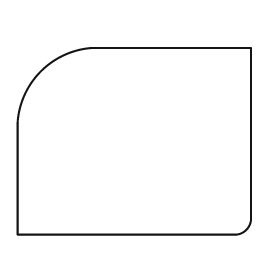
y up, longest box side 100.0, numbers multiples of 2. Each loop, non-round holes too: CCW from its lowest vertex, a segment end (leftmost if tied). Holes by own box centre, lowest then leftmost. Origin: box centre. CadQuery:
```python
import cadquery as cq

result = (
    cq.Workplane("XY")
    .moveTo(-50.0, -40.0)
    .lineTo(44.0, -40.0)
    .threePointArc((48.0, -38.0), (50.0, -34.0))
    .lineTo(50.0, 40.0)
    .lineTo(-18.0, 40.0)
    .threePointArc((-40.0, 30.0), (-50.0, 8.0))
    .close()
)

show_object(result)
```